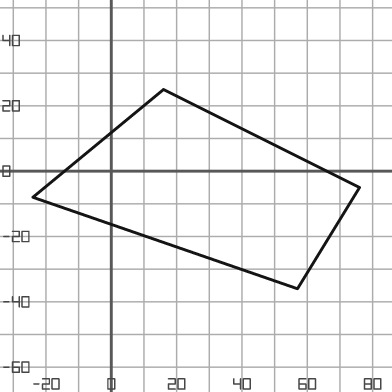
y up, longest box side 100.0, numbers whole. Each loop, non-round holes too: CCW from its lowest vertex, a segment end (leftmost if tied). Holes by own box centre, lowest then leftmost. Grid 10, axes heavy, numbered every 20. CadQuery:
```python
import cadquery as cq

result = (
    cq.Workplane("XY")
    .moveTo(57.0, -36.0)
    .lineTo(76.0, -5.0)
    .lineTo(16.0, 25.0)
    .lineTo(-24.0, -8.0)
    .close()
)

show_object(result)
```